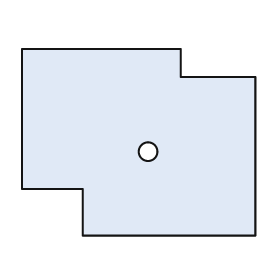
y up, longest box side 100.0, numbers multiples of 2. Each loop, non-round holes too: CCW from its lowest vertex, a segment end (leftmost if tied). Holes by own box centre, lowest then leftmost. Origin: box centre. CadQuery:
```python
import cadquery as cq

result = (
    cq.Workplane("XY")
    .moveTo(-24.0, -40.0)
    .lineTo(50.0, -40.0)
    .lineTo(50.0, 28.0)
    .lineTo(18.0, 28.0)
    .lineTo(18.0, 40.0)
    .lineTo(-50.0, 40.0)
    .lineTo(-50.0, -20.0)
    .lineTo(-24.0, -20.0)
    .close()
    .moveTo(4.0, -4.0)
    .circle(4.0)
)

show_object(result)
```